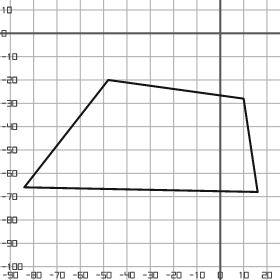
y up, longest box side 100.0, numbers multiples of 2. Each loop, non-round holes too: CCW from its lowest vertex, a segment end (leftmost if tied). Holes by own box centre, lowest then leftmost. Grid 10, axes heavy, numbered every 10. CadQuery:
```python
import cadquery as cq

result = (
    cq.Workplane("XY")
    .moveTo(16.0, -68.0)
    .lineTo(10.0, -28.0)
    .lineTo(-48.0, -20.0)
    .lineTo(-84.0, -66.0)
    .close()
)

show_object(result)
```